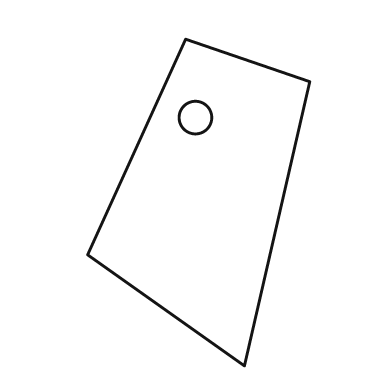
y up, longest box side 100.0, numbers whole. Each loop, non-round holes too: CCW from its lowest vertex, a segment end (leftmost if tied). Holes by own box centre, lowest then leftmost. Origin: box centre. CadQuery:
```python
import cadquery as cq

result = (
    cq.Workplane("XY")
    .moveTo(14.0, -50.0)
    .lineTo(34.0, 37.0)
    .lineTo(-4.0, 50.0)
    .lineTo(-34.0, -16.0)
    .close()
    .moveTo(-1.0, 26.0)
    .circle(5.0)
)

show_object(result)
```